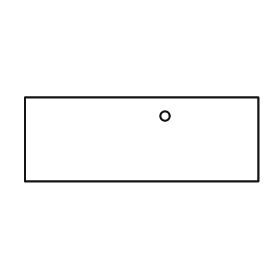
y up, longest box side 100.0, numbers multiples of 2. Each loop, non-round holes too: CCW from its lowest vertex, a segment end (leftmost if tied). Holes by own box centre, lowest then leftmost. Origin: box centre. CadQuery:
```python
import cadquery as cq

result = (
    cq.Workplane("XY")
    .moveTo(-50.0, -18.0)
    .lineTo(50.0, -18.0)
    .lineTo(50.0, 18.0)
    .lineTo(-50.0, 18.0)
    .close()
    .moveTo(10.0, 10.0)
    .circle(2.0)
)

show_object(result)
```